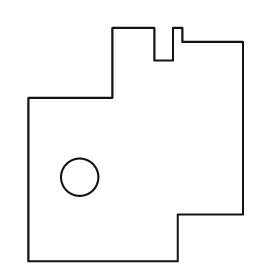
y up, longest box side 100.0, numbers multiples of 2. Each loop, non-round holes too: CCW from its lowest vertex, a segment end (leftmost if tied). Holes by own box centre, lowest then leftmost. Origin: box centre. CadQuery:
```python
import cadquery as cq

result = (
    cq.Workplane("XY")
    .moveTo(-46.0, -50.0)
    .lineTo(18.0, -50.0)
    .lineTo(18.0, -30.0)
    .lineTo(46.0, -30.0)
    .lineTo(46.0, 44.0)
    .lineTo(20.0, 44.0)
    .lineTo(20.0, 50.0)
    .lineTo(16.0, 50.0)
    .lineTo(16.0, 36.0)
    .lineTo(8.0, 36.0)
    .lineTo(8.0, 50.0)
    .lineTo(-10.0, 50.0)
    .lineTo(-10.0, 20.0)
    .lineTo(-46.0, 20.0)
    .close()
    .moveTo(-24.0, -14.0)
    .circle(8.0)
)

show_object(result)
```